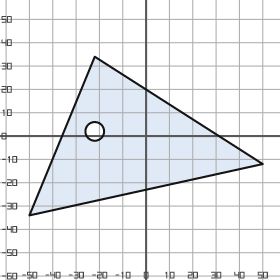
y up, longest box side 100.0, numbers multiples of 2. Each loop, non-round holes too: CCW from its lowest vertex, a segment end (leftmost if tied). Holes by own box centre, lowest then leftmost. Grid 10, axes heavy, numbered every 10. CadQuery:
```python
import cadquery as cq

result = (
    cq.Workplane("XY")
    .moveTo(-50.0, -34.0)
    .lineTo(50.0, -12.0)
    .lineTo(-22.0, 34.0)
    .close()
    .moveTo(-22.0, 2.0)
    .circle(4.0)
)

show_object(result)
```